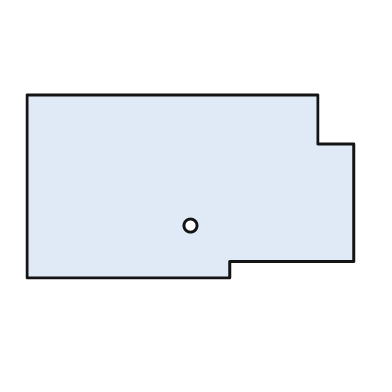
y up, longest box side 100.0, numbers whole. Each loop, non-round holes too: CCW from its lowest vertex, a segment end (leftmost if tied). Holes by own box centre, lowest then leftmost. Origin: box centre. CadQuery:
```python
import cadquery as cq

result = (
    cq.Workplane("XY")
    .moveTo(-50.0, -28.0)
    .lineTo(12.0, -28.0)
    .lineTo(12.0, -23.0)
    .lineTo(50.0, -23.0)
    .lineTo(50.0, 13.0)
    .lineTo(39.0, 13.0)
    .lineTo(39.0, 28.0)
    .lineTo(-50.0, 28.0)
    .close()
    .moveTo(0.0, -12.0)
    .circle(2.0)
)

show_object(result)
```